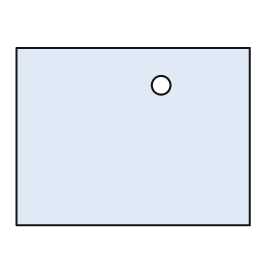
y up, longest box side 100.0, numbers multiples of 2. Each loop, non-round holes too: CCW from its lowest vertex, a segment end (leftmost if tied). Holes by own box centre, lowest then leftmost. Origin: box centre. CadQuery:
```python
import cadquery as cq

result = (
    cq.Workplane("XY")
    .moveTo(-50.0, -38.0)
    .lineTo(50.0, -38.0)
    .lineTo(50.0, 38.0)
    .lineTo(-50.0, 38.0)
    .close()
    .moveTo(12.0, 22.0)
    .circle(4.0)
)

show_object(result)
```